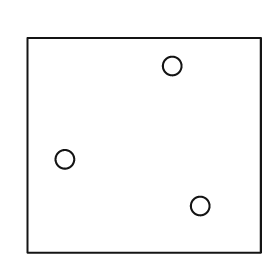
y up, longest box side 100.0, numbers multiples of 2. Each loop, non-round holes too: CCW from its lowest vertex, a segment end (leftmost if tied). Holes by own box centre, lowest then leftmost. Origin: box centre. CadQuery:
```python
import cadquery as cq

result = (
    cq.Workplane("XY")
    .moveTo(-50.0, -46.0)
    .lineTo(50.0, -46.0)
    .lineTo(50.0, 46.0)
    .lineTo(-50.0, 46.0)
    .close()
    .moveTo(24.0, -26.0)
    .circle(4.0)
    .moveTo(-34.0, -6.0)
    .circle(4.0)
    .moveTo(12.0, 34.0)
    .circle(4.0)
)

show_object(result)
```